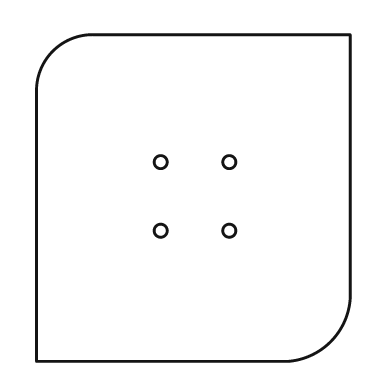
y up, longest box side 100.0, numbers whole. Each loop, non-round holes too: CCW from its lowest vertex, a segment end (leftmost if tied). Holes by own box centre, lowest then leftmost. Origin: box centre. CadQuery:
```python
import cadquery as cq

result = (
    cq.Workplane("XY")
    .moveTo(-48.0, -50.0)
    .lineTo(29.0, -50.0)
    .threePointArc((42.0, -44.0), (48.0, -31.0))
    .lineTo(48.0, 50.0)
    .lineTo(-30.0, 50.0)
    .threePointArc((-43.0, 45.0), (-48.0, 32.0))
    .close()
    .moveTo(-10.0, -10.0)
    .circle(2.0)
    .moveTo(11.0, -10.0)
    .circle(2.0)
    .moveTo(-10.0, 11.0)
    .circle(2.0)
    .moveTo(11.0, 11.0)
    .circle(2.0)
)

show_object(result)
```